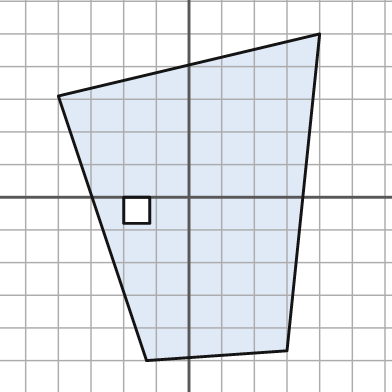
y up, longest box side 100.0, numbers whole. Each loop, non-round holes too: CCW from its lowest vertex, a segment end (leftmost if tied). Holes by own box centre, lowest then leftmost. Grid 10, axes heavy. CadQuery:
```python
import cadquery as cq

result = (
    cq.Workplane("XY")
    .moveTo(-13.0, -50.0)
    .lineTo(30.0, -47.0)
    .lineTo(40.0, 50.0)
    .lineTo(-40.0, 31.0)
    .close()
    .moveTo(-20.0, -8.0)
    .lineTo(-12.0, -8.0)
    .lineTo(-12.0, 0.0)
    .lineTo(-20.0, 0.0)
    .close()
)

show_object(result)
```